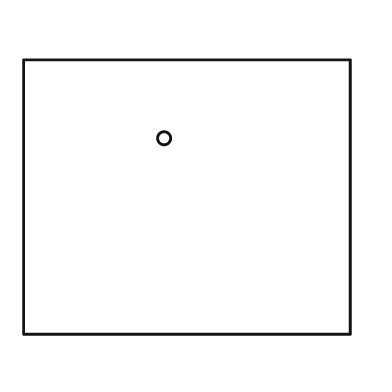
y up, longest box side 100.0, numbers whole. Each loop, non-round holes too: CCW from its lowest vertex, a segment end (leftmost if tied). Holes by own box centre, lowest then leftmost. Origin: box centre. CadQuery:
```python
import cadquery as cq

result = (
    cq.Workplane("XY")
    .moveTo(-50.0, -42.0)
    .lineTo(50.0, -42.0)
    .lineTo(50.0, 42.0)
    .lineTo(-50.0, 42.0)
    .close()
    .moveTo(-7.0, 18.0)
    .circle(2.0)
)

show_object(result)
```